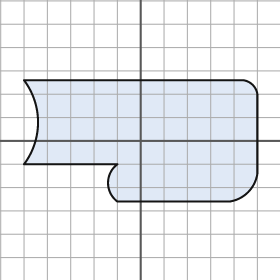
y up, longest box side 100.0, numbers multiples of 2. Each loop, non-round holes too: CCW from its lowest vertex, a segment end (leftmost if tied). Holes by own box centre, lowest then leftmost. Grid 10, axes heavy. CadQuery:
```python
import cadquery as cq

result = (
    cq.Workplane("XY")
    .moveTo(-10.0, -26.0)
    .lineTo(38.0, -26.0)
    .threePointArc((46.0, -22.0), (50.0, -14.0))
    .lineTo(50.0, 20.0)
    .threePointArc((48.0, 24.0), (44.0, 26.0))
    .lineTo(-50.0, 26.0)
    .threePointArc((-44.0, 8.0), (-50.0, -10.0))
    .lineTo(-10.0, -10.0)
    .threePointArc((-14.0, -18.0), (-10.0, -26.0))
    .close()
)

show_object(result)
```